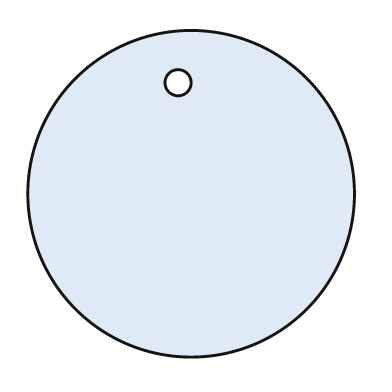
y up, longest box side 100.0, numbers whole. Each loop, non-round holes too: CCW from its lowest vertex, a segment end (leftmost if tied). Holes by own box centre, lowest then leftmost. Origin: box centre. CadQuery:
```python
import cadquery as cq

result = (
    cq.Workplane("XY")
    .moveTo(0.0, 0.0)
    .circle(50.0)
    .moveTo(-4.0, 34.0)
    .circle(4.0)
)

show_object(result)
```